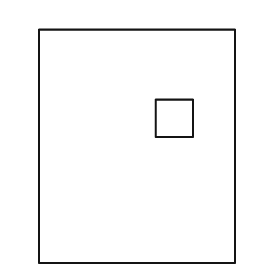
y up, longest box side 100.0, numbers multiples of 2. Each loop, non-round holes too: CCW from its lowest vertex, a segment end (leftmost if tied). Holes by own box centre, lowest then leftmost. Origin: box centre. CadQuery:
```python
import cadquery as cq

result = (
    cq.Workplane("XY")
    .moveTo(-42.0, -50.0)
    .lineTo(42.0, -50.0)
    .lineTo(42.0, 50.0)
    .lineTo(-42.0, 50.0)
    .close()
    .moveTo(8.0, 4.0)
    .lineTo(24.0, 4.0)
    .lineTo(24.0, 20.0)
    .lineTo(8.0, 20.0)
    .close()
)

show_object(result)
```